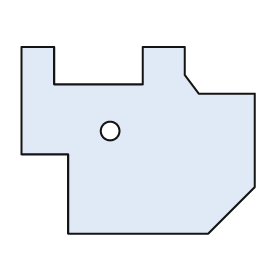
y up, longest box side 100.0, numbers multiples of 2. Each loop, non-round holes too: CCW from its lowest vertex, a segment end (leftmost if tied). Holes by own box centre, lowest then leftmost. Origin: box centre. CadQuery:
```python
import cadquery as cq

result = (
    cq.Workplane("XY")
    .moveTo(-30.0, -40.0)
    .lineTo(30.0, -40.0)
    .lineTo(50.0, -20.0)
    .lineTo(50.0, 20.0)
    .lineTo(26.0, 20.0)
    .lineTo(20.0, 28.0)
    .lineTo(20.0, 40.0)
    .lineTo(2.0, 40.0)
    .lineTo(2.0, 24.0)
    .lineTo(-36.0, 24.0)
    .lineTo(-36.0, 40.0)
    .lineTo(-50.0, 40.0)
    .lineTo(-50.0, -6.0)
    .lineTo(-30.0, -6.0)
    .close()
    .moveTo(-12.0, 4.0)
    .circle(4.0)
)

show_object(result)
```